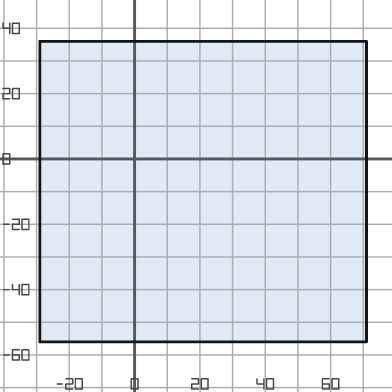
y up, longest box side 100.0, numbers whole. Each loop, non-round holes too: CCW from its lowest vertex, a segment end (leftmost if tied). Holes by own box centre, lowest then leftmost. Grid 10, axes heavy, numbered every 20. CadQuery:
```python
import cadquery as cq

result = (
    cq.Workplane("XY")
    .moveTo(-29.0, -56.0)
    .lineTo(71.0, -56.0)
    .lineTo(71.0, 36.0)
    .lineTo(-29.0, 36.0)
    .close()
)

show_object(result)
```